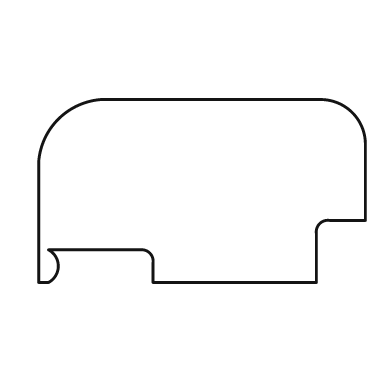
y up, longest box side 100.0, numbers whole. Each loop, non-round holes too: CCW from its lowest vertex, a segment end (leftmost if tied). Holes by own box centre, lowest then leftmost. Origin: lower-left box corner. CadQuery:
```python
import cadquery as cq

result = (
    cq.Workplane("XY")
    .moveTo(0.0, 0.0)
    .lineTo(3.0, 0.0)
    .threePointArc((6.0, 5.0), (3.0, 10.0))
    .lineTo(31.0, 10.0)
    .threePointArc((34.0, 9.0), (35.0, 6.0))
    .lineTo(35.0, 0.0)
    .lineTo(85.0, 0.0)
    .lineTo(85.0, 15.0)
    .threePointArc((86.0, 18.0), (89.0, 19.0))
    .lineTo(100.0, 19.0)
    .lineTo(100.0, 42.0)
    .threePointArc((96.0, 52.0), (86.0, 56.0))
    .lineTo(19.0, 56.0)
    .threePointArc((6.0, 50.0), (0.0, 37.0))
    .close()
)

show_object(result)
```